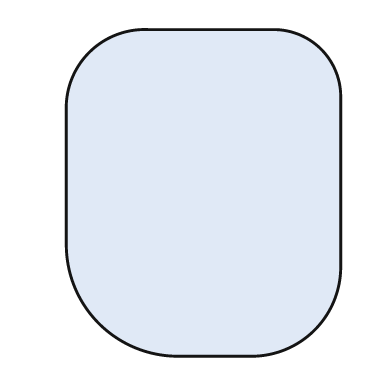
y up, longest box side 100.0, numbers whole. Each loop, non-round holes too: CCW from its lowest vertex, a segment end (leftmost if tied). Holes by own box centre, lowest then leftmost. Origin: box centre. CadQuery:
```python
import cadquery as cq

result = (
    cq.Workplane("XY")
    .moveTo(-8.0, -50.0)
    .lineTo(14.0, -50.0)
    .threePointArc((34.0, -42.0), (42.0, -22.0))
    .lineTo(42.0, 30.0)
    .threePointArc((36.0, 44.0), (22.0, 50.0))
    .lineTo(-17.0, 50.0)
    .threePointArc((-35.0, 43.0), (-42.0, 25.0))
    .lineTo(-42.0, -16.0)
    .threePointArc((-32.0, -40.0), (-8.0, -50.0))
    .close()
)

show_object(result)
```